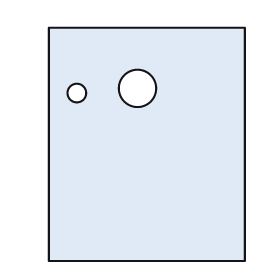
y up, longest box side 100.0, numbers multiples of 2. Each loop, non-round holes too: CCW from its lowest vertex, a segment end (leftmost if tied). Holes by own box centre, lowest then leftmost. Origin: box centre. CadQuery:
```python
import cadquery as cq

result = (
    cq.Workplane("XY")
    .moveTo(-42.0, -50.0)
    .lineTo(42.0, -50.0)
    .lineTo(42.0, 50.0)
    .lineTo(-42.0, 50.0)
    .close()
    .moveTo(-30.0, 22.0)
    .circle(4.0)
    .moveTo(-4.0, 24.0)
    .circle(8.0)
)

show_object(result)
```